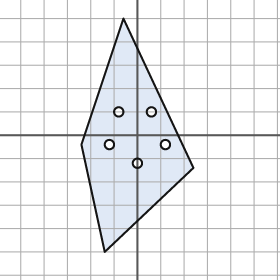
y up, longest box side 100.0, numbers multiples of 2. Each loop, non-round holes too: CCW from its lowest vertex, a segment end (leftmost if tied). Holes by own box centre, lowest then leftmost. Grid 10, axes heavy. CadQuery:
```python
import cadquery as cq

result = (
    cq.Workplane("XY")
    .moveTo(-14.0, -50.0)
    .lineTo(24.0, -14.0)
    .lineTo(-6.0, 50.0)
    .lineTo(-24.0, -4.0)
    .close()
    .moveTo(0.0, -12.0)
    .circle(2.0)
    .moveTo(-12.0, -4.0)
    .circle(2.0)
    .moveTo(12.0, -4.0)
    .circle(2.0)
    .moveTo(-8.0, 10.0)
    .circle(2.0)
    .moveTo(6.0, 10.0)
    .circle(2.0)
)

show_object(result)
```